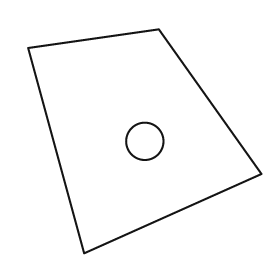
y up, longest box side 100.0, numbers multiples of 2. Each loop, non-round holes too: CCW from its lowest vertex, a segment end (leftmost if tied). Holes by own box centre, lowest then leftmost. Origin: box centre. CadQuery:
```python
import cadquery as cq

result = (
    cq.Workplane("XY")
    .moveTo(-26.0, -48.0)
    .lineTo(50.0, -14.0)
    .lineTo(6.0, 48.0)
    .lineTo(-50.0, 40.0)
    .close()
    .moveTo(0.0, 0.0)
    .circle(8.0)
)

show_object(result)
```